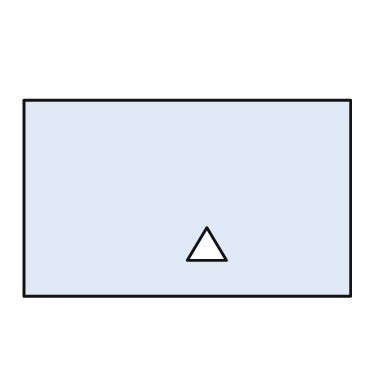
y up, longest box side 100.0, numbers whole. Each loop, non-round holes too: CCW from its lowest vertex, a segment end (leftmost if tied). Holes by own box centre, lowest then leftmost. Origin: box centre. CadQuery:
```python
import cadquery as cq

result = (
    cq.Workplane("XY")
    .moveTo(-50.0, -30.0)
    .lineTo(50.0, -30.0)
    .lineTo(50.0, 30.0)
    .lineTo(-50.0, 30.0)
    .close()
    .moveTo(0.0, -19.0)
    .lineTo(12.0, -19.0)
    .lineTo(6.0, -9.0)
    .close()
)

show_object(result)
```